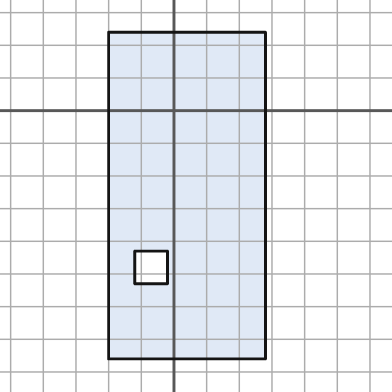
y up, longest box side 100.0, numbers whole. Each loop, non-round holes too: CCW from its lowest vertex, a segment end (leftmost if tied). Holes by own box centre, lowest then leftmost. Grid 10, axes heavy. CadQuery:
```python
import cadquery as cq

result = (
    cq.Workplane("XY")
    .moveTo(-20.0, -76.0)
    .lineTo(28.0, -76.0)
    .lineTo(28.0, 24.0)
    .lineTo(-20.0, 24.0)
    .close()
    .moveTo(-12.0, -53.0)
    .lineTo(-2.0, -53.0)
    .lineTo(-2.0, -43.0)
    .lineTo(-12.0, -43.0)
    .close()
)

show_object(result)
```